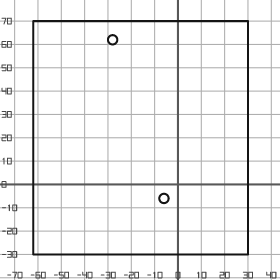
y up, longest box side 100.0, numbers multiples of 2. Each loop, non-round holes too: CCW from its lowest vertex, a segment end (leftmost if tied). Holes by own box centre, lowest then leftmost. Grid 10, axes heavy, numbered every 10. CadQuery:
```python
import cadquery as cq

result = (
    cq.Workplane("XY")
    .moveTo(-62.0, -30.0)
    .lineTo(30.0, -30.0)
    .lineTo(30.0, 70.0)
    .lineTo(-62.0, 70.0)
    .close()
    .moveTo(-6.0, -6.0)
    .circle(2.0)
    .moveTo(-28.0, 62.0)
    .circle(2.0)
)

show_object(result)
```